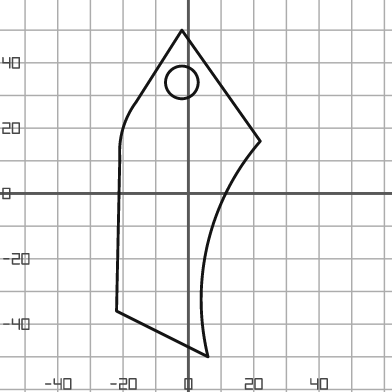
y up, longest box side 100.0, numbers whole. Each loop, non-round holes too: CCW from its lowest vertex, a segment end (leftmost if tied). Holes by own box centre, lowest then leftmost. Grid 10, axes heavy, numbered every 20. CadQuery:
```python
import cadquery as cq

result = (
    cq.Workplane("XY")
    .moveTo(6.0, -50.0)
    .threePointArc((6.0, -15.0), (22.0, 16.0))
    .lineTo(-2.0, 50.0)
    .lineTo(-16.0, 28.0)
    .threePointArc((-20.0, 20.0), (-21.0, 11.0))
    .lineTo(-22.0, -36.0)
    .close()
    .moveTo(-2.0, 34.0)
    .circle(5.0)
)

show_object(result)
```